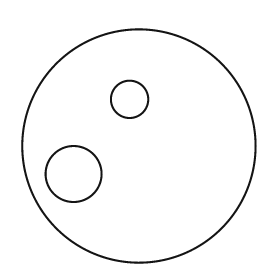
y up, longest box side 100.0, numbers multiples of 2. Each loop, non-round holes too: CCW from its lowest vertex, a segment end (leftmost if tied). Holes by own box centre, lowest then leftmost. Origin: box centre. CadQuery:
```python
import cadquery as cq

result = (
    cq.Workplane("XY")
    .moveTo(0.0, 0.0)
    .circle(50.0)
    .moveTo(-28.0, -12.0)
    .circle(12.0)
    .moveTo(-4.0, 20.0)
    .circle(8.0)
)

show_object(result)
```